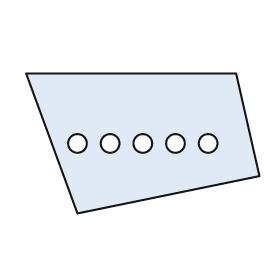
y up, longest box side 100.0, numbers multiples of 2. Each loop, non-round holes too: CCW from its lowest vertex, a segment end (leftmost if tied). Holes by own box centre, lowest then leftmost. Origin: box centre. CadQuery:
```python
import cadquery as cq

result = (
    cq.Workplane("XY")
    .moveTo(-28.0, -30.0)
    .lineTo(50.0, -14.0)
    .lineTo(40.0, 30.0)
    .lineTo(-50.0, 30.0)
    .close()
    .moveTo(-28.0, 0.0)
    .circle(4.0)
    .moveTo(-14.0, 0.0)
    .circle(4.0)
    .moveTo(0.0, 0.0)
    .circle(4.0)
    .moveTo(14.0, 0.0)
    .circle(4.0)
    .moveTo(28.0, 0.0)
    .circle(4.0)
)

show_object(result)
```